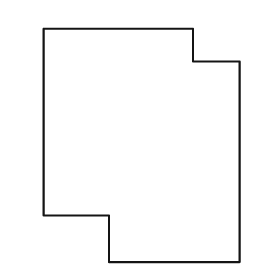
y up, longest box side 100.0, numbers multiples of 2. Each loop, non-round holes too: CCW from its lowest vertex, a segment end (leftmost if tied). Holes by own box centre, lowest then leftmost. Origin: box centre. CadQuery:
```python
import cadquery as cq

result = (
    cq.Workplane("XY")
    .moveTo(-14.0, -50.0)
    .lineTo(42.0, -50.0)
    .lineTo(42.0, 36.0)
    .lineTo(22.0, 36.0)
    .lineTo(22.0, 50.0)
    .lineTo(-42.0, 50.0)
    .lineTo(-42.0, -30.0)
    .lineTo(-14.0, -30.0)
    .close()
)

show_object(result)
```